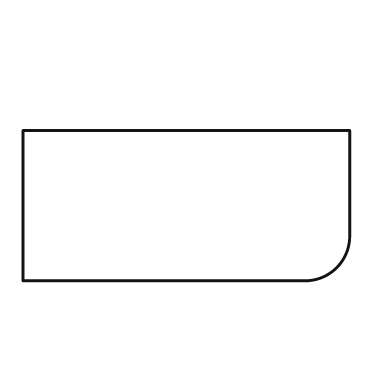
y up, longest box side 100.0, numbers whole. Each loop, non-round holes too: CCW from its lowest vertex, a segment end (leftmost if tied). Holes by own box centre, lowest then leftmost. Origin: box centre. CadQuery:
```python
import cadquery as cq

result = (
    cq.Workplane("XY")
    .moveTo(-50.0, -23.0)
    .lineTo(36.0, -23.0)
    .threePointArc((46.0, -19.0), (50.0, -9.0))
    .lineTo(50.0, 23.0)
    .lineTo(-50.0, 23.0)
    .close()
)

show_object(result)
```